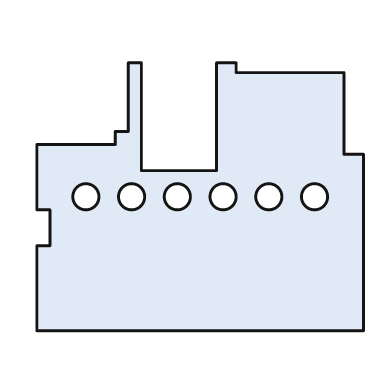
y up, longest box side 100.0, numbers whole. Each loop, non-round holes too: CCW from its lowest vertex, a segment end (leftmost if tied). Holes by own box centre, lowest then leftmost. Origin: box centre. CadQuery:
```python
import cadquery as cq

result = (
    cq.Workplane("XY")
    .moveTo(-50.0, -41.0)
    .lineTo(50.0, -41.0)
    .lineTo(50.0, 13.0)
    .lineTo(44.0, 13.0)
    .lineTo(44.0, 38.0)
    .lineTo(11.0, 38.0)
    .lineTo(11.0, 41.0)
    .lineTo(5.0, 41.0)
    .lineTo(5.0, 8.0)
    .lineTo(-18.0, 8.0)
    .lineTo(-18.0, 41.0)
    .lineTo(-22.0, 41.0)
    .lineTo(-22.0, 20.0)
    .lineTo(-26.0, 20.0)
    .lineTo(-26.0, 16.0)
    .lineTo(-50.0, 16.0)
    .lineTo(-50.0, -4.0)
    .lineTo(-46.0, -4.0)
    .lineTo(-46.0, -15.0)
    .lineTo(-50.0, -15.0)
    .close()
    .moveTo(-35.0, 0.0)
    .circle(4.0)
    .moveTo(-21.0, 0.0)
    .circle(4.0)
    .moveTo(-7.0, 0.0)
    .circle(4.0)
    .moveTo(7.0, 0.0)
    .circle(4.0)
    .moveTo(21.0, 0.0)
    .circle(4.0)
    .moveTo(35.0, 0.0)
    .circle(4.0)
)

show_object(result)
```